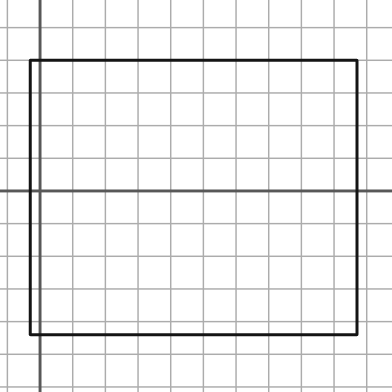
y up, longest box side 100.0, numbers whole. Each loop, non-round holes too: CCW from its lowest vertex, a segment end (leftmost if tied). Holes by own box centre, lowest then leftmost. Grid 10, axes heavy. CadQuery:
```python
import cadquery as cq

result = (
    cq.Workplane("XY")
    .moveTo(-3.0, -44.0)
    .lineTo(97.0, -44.0)
    .lineTo(97.0, 40.0)
    .lineTo(-3.0, 40.0)
    .close()
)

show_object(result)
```